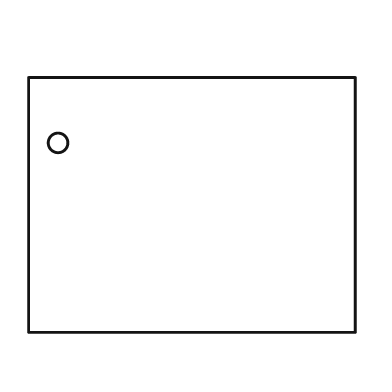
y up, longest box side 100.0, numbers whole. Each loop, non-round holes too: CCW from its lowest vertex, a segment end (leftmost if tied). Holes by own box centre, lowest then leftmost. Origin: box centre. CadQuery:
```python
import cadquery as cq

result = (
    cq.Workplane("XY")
    .moveTo(-50.0, -39.0)
    .lineTo(50.0, -39.0)
    .lineTo(50.0, 39.0)
    .lineTo(-50.0, 39.0)
    .close()
    .moveTo(-41.0, 19.0)
    .circle(3.0)
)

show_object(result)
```